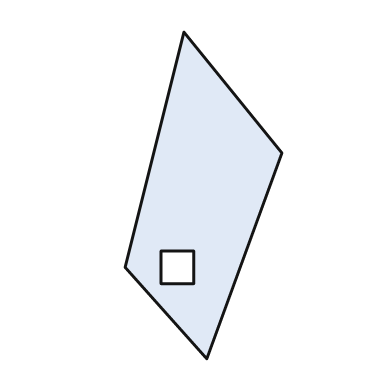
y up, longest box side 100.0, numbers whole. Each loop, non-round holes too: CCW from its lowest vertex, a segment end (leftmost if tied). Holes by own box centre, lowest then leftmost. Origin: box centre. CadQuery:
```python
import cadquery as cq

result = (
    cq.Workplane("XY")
    .moveTo(1.0, -50.0)
    .lineTo(24.0, 13.0)
    .lineTo(-6.0, 50.0)
    .lineTo(-24.0, -22.0)
    .close()
    .moveTo(-13.0, -27.0)
    .lineTo(-3.0, -27.0)
    .lineTo(-3.0, -17.0)
    .lineTo(-13.0, -17.0)
    .close()
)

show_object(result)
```